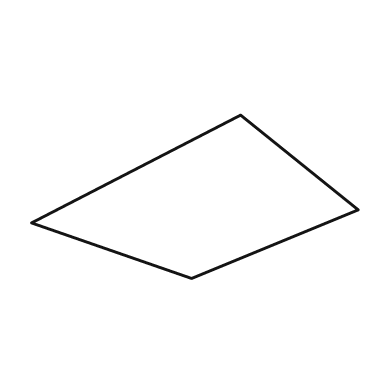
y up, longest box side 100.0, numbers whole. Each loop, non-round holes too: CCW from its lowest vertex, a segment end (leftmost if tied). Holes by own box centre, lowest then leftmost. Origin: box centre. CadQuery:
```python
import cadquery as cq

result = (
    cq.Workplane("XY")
    .moveTo(-1.0, -25.0)
    .lineTo(50.0, -4.0)
    .lineTo(14.0, 25.0)
    .lineTo(-50.0, -8.0)
    .close()
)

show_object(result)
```